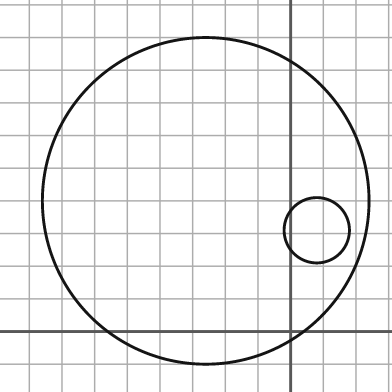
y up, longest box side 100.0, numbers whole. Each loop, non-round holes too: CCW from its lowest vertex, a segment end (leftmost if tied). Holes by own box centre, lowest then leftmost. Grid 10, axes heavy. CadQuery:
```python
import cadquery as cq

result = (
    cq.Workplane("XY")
    .moveTo(-26.0, 40.0)
    .circle(50.0)
    .moveTo(8.0, 31.0)
    .circle(10.0)
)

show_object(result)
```